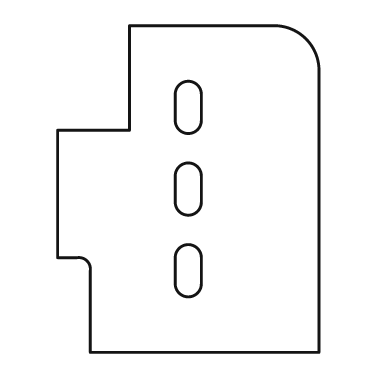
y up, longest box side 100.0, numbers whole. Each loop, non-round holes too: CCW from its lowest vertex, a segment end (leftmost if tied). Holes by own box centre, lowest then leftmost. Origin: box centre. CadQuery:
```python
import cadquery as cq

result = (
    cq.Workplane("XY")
    .moveTo(-30.0, -50.0)
    .lineTo(40.0, -50.0)
    .lineTo(40.0, 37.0)
    .threePointArc((36.0, 46.0), (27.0, 50.0))
    .lineTo(-18.0, 50.0)
    .lineTo(-18.0, 18.0)
    .lineTo(-40.0, 18.0)
    .lineTo(-40.0, -21.0)
    .lineTo(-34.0, -21.0)
    .threePointArc((-31.0, -22.0), (-30.0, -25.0))
    .close()
    .moveTo(-4.0, -29.0)
    .threePointArc((0.0, -33.0), (4.0, -29.0))
    .lineTo(4.0, -21.0)
    .threePointArc((0.0, -17.0), (-4.0, -21.0))
    .close()
    .moveTo(-4.0, -4.0)
    .threePointArc((0.0, -8.0), (4.0, -4.0))
    .lineTo(4.0, 4.0)
    .threePointArc((0.0, 8.0), (-4.0, 4.0))
    .close()
    .moveTo(-4.0, 21.0)
    .threePointArc((0.0, 17.0), (4.0, 21.0))
    .lineTo(4.0, 29.0)
    .threePointArc((0.0, 33.0), (-4.0, 29.0))
    .close()
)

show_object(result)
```